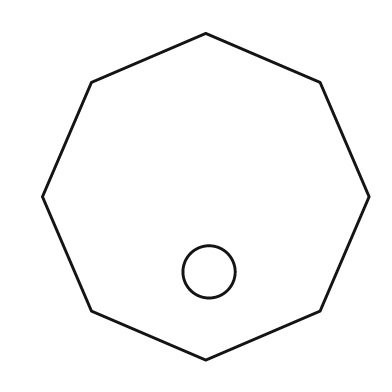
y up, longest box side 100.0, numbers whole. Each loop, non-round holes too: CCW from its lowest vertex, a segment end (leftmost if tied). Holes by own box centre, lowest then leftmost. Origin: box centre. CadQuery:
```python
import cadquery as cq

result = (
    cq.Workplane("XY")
    .moveTo(0.0, -50.0)
    .lineTo(35.0, -35.0)
    .lineTo(50.0, 0.0)
    .lineTo(35.0, 35.0)
    .lineTo(0.0, 50.0)
    .lineTo(-35.0, 35.0)
    .lineTo(-50.0, 0.0)
    .lineTo(-35.0, -35.0)
    .close()
    .moveTo(1.0, -23.0)
    .circle(8.0)
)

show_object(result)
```